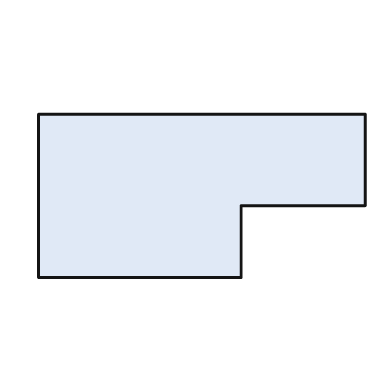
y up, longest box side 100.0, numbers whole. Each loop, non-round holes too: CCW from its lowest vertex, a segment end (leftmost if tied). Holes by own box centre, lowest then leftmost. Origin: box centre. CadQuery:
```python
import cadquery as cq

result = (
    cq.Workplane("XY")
    .moveTo(-50.0, -25.0)
    .lineTo(12.0, -25.0)
    .lineTo(12.0, -3.0)
    .lineTo(50.0, -3.0)
    .lineTo(50.0, 25.0)
    .lineTo(-50.0, 25.0)
    .close()
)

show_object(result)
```